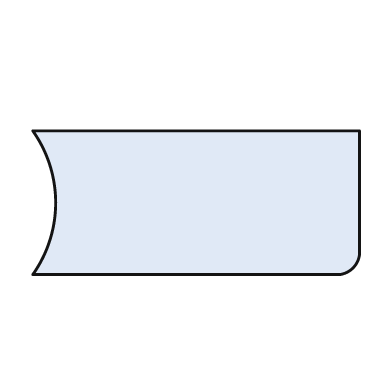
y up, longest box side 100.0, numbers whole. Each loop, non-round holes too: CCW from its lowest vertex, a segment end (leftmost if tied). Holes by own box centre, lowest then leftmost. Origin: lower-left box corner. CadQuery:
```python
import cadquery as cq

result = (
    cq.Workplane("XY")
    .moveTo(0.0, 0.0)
    .lineTo(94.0, 0.0)
    .threePointArc((98.0, 2.0), (100.0, 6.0))
    .lineTo(100.0, 44.0)
    .lineTo(0.0, 44.0)
    .threePointArc((7.0, 22.0), (0.0, 0.0))
    .close()
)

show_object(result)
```